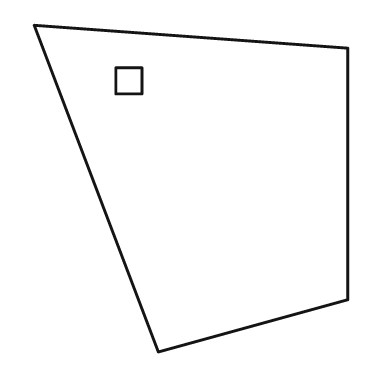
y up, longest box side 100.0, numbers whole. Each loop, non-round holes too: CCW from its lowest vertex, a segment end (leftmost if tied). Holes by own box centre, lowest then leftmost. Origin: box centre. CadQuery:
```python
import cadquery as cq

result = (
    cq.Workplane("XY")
    .moveTo(-10.0, -50.0)
    .lineTo(48.0, -34.0)
    .lineTo(48.0, 43.0)
    .lineTo(-48.0, 50.0)
    .close()
    .moveTo(-23.0, 29.0)
    .lineTo(-15.0, 29.0)
    .lineTo(-15.0, 37.0)
    .lineTo(-23.0, 37.0)
    .close()
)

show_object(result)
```